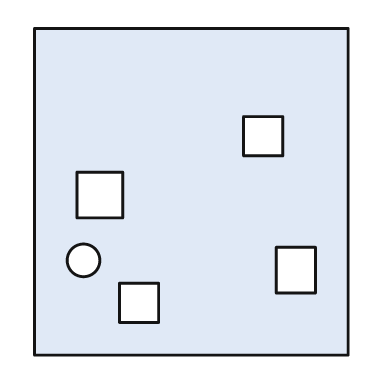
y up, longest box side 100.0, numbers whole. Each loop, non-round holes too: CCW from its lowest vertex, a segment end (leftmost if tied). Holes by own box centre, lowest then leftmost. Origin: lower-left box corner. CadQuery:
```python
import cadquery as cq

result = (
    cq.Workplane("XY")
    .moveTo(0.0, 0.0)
    .lineTo(96.0, 0.0)
    .lineTo(96.0, 100.0)
    .lineTo(0.0, 100.0)
    .close()
    .moveTo(26.0, 10.0)
    .lineTo(38.0, 10.0)
    .lineTo(38.0, 22.0)
    .lineTo(26.0, 22.0)
    .close()
    .moveTo(74.0, 19.0)
    .lineTo(86.0, 19.0)
    .lineTo(86.0, 33.0)
    .lineTo(74.0, 33.0)
    .close()
    .moveTo(15.0, 29.0)
    .circle(5.0)
    .moveTo(13.0, 42.0)
    .lineTo(27.0, 42.0)
    .lineTo(27.0, 56.0)
    .lineTo(13.0, 56.0)
    .close()
    .moveTo(64.0, 61.0)
    .lineTo(76.0, 61.0)
    .lineTo(76.0, 73.0)
    .lineTo(64.0, 73.0)
    .close()
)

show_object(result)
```